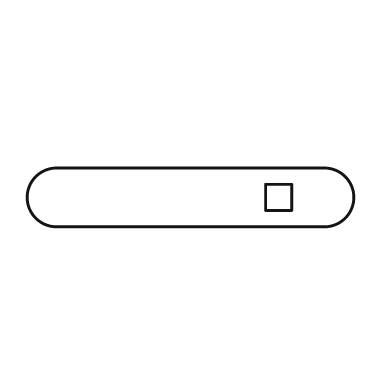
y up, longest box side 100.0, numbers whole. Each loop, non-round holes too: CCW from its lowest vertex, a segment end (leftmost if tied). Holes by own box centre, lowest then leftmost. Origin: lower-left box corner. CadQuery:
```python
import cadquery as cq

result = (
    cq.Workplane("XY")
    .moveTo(9.0, 0.0)
    .lineTo(91.0, 0.0)
    .threePointArc((100.0, 9.0), (91.0, 18.0))
    .lineTo(9.0, 18.0)
    .threePointArc((0.0, 9.0), (9.0, 0.0))
    .close()
    .moveTo(73.0, 5.0)
    .lineTo(81.0, 5.0)
    .lineTo(81.0, 13.0)
    .lineTo(73.0, 13.0)
    .close()
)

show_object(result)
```